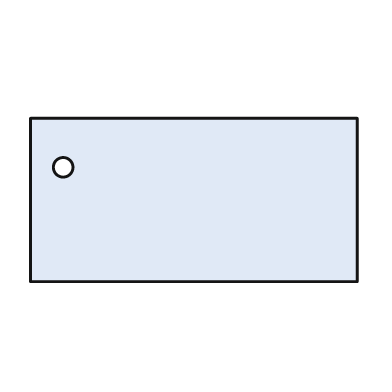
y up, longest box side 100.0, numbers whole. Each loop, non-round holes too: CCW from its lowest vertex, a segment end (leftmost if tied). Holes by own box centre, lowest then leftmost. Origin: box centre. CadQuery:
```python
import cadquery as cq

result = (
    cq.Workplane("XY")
    .moveTo(-50.0, -25.0)
    .lineTo(50.0, -25.0)
    .lineTo(50.0, 25.0)
    .lineTo(-50.0, 25.0)
    .close()
    .moveTo(-40.0, 10.0)
    .circle(3.0)
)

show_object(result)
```